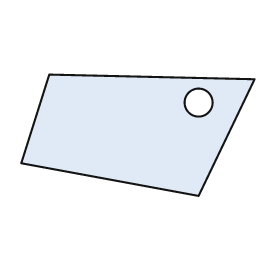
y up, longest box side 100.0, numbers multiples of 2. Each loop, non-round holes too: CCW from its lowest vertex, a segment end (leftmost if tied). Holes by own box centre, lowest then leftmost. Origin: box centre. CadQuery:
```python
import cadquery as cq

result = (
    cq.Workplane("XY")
    .moveTo(26.0, -26.0)
    .lineTo(50.0, 24.0)
    .lineTo(-38.0, 26.0)
    .lineTo(-50.0, -12.0)
    .close()
    .moveTo(26.0, 14.0)
    .circle(6.0)
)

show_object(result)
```